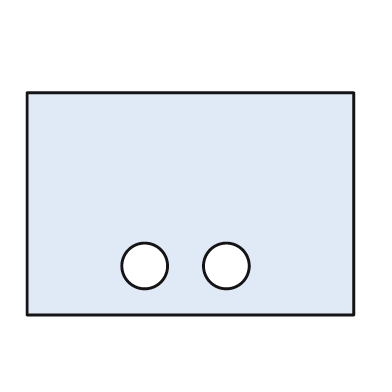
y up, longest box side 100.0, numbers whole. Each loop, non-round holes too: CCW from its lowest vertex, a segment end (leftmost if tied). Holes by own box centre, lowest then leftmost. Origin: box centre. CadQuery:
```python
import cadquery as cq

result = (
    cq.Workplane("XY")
    .moveTo(-50.0, -34.0)
    .lineTo(50.0, -34.0)
    .lineTo(50.0, 34.0)
    .lineTo(-50.0, 34.0)
    .close()
    .moveTo(-14.0, -19.0)
    .circle(7.0)
    .moveTo(11.0, -19.0)
    .circle(7.0)
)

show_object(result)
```